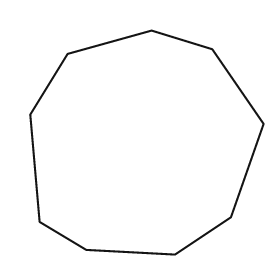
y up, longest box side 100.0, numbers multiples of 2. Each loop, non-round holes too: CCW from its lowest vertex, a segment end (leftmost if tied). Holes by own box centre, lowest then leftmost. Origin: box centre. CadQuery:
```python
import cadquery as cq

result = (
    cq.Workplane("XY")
    .moveTo(12.0, -48.0)
    .lineTo(36.0, -32.0)
    .lineTo(50.0, 8.0)
    .lineTo(28.0, 40.0)
    .lineTo(2.0, 48.0)
    .lineTo(-34.0, 38.0)
    .lineTo(-50.0, 12.0)
    .lineTo(-46.0, -34.0)
    .lineTo(-26.0, -46.0)
    .close()
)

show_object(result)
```